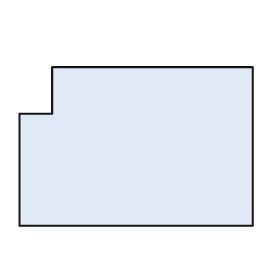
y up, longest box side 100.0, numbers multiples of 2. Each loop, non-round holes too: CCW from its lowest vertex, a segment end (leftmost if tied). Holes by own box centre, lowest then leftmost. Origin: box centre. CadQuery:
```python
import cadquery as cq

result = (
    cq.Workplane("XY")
    .moveTo(-50.0, -34.0)
    .lineTo(50.0, -34.0)
    .lineTo(50.0, 34.0)
    .lineTo(-36.0, 34.0)
    .lineTo(-36.0, 14.0)
    .lineTo(-50.0, 14.0)
    .close()
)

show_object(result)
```